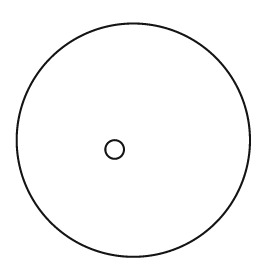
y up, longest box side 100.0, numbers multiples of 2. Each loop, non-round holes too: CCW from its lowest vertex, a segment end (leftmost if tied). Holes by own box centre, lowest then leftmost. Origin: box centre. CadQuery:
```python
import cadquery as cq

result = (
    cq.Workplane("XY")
    .moveTo(0.0, 0.0)
    .circle(50.0)
    .moveTo(-8.0, -4.0)
    .circle(4.0)
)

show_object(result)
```